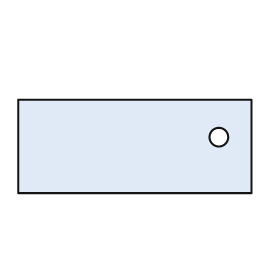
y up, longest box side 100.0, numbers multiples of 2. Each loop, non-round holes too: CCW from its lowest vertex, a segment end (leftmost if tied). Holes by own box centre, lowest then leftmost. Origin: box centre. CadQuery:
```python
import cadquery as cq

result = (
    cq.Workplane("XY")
    .moveTo(-50.0, -20.0)
    .lineTo(50.0, -20.0)
    .lineTo(50.0, 20.0)
    .lineTo(-50.0, 20.0)
    .close()
    .moveTo(36.0, 4.0)
    .circle(4.0)
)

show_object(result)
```